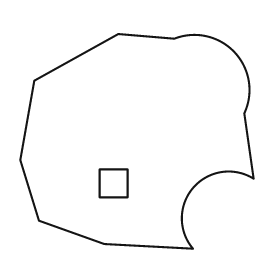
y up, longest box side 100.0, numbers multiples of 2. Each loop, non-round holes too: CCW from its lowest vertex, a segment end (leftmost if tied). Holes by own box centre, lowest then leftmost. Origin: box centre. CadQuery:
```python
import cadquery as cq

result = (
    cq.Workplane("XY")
    .moveTo(24.0, -46.0)
    .threePointArc((24.0, -20.0), (50.0, -16.0))
    .lineTo(46.0, 12.0)
    .threePointArc((42.0, 38.0), (16.0, 44.0))
    .lineTo(-8.0, 46.0)
    .lineTo(-44.0, 26.0)
    .lineTo(-50.0, -8.0)
    .lineTo(-42.0, -34.0)
    .lineTo(-14.0, -44.0)
    .close()
    .moveTo(-16.0, -24.0)
    .lineTo(-4.0, -24.0)
    .lineTo(-4.0, -12.0)
    .lineTo(-16.0, -12.0)
    .close()
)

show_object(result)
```